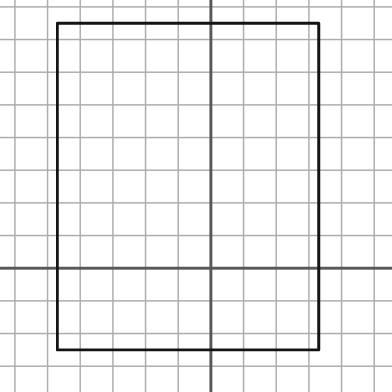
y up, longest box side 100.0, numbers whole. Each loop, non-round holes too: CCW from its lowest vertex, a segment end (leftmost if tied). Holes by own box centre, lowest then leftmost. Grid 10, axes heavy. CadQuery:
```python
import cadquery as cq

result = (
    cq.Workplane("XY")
    .moveTo(-47.0, -25.0)
    .lineTo(33.0, -25.0)
    .lineTo(33.0, 75.0)
    .lineTo(-47.0, 75.0)
    .close()
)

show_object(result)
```